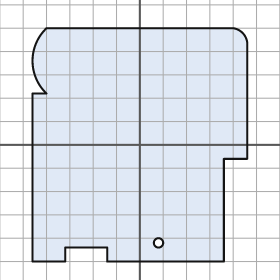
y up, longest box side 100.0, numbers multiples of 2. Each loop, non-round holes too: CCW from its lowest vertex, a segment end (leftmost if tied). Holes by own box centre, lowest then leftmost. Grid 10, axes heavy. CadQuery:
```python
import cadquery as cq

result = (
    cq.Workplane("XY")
    .moveTo(-46.0, -50.0)
    .lineTo(-32.0, -50.0)
    .lineTo(-32.0, -44.0)
    .lineTo(-14.0, -44.0)
    .lineTo(-14.0, -50.0)
    .lineTo(36.0, -50.0)
    .lineTo(36.0, -6.0)
    .lineTo(46.0, -6.0)
    .lineTo(46.0, 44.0)
    .threePointArc((44.0, 48.0), (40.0, 50.0))
    .lineTo(-40.0, 50.0)
    .threePointArc((-46.0, 36.0), (-40.0, 22.0))
    .lineTo(-46.0, 22.0)
    .close()
    .moveTo(8.0, -42.0)
    .circle(2.0)
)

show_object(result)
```